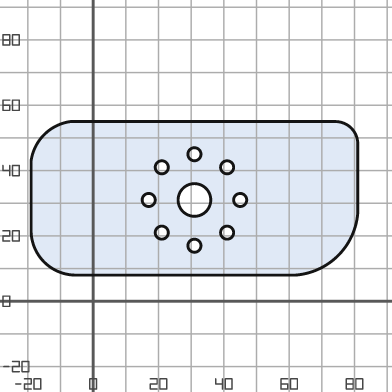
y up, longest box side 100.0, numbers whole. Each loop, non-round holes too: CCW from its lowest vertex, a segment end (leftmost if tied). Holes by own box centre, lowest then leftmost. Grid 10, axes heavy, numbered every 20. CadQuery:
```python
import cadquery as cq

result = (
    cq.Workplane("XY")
    .moveTo(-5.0, 8.0)
    .lineTo(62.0, 8.0)
    .threePointArc((75.0, 14.0), (81.0, 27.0))
    .lineTo(81.0, 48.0)
    .threePointArc((79.0, 53.0), (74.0, 55.0))
    .lineTo(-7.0, 55.0)
    .threePointArc((-15.0, 51.0), (-19.0, 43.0))
    .lineTo(-19.0, 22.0)
    .threePointArc((-15.0, 12.0), (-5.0, 8.0))
    .close()
    .moveTo(31.0, 17.0)
    .circle(2.0)
    .moveTo(21.0, 21.0)
    .circle(2.0)
    .moveTo(41.0, 21.0)
    .circle(2.0)
    .moveTo(17.0, 31.0)
    .circle(2.0)
    .moveTo(31.0, 31.0)
    .circle(5.0)
    .moveTo(45.0, 31.0)
    .circle(2.0)
    .moveTo(21.0, 41.0)
    .circle(2.0)
    .moveTo(41.0, 41.0)
    .circle(2.0)
    .moveTo(31.0, 45.0)
    .circle(2.0)
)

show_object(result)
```